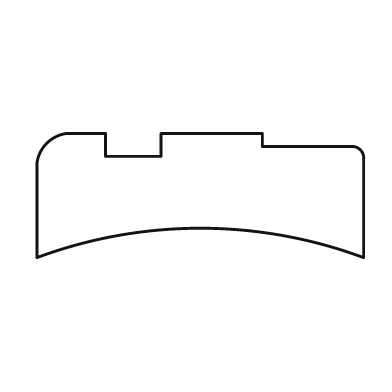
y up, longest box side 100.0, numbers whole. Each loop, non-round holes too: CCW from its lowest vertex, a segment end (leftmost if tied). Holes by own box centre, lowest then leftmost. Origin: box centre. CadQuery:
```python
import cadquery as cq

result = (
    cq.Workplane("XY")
    .moveTo(-50.0, -19.0)
    .threePointArc((0.0, -10.0), (50.0, -19.0))
    .lineTo(50.0, 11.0)
    .threePointArc((49.0, 14.0), (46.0, 15.0))
    .lineTo(19.0, 15.0)
    .lineTo(19.0, 19.0)
    .lineTo(-12.0, 19.0)
    .lineTo(-12.0, 12.0)
    .lineTo(-29.0, 12.0)
    .lineTo(-29.0, 19.0)
    .lineTo(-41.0, 19.0)
    .threePointArc((-47.0, 16.0), (-50.0, 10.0))
    .close()
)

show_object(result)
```